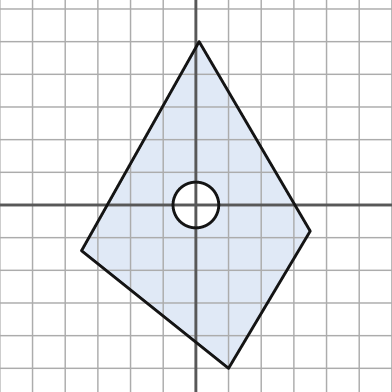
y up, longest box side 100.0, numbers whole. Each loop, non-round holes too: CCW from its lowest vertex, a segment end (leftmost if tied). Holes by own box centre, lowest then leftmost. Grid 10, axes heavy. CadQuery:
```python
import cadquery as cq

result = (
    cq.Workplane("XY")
    .moveTo(10.0, -50.0)
    .lineTo(35.0, -8.0)
    .lineTo(1.0, 50.0)
    .lineTo(-35.0, -14.0)
    .close()
    .moveTo(0.0, 0.0)
    .circle(7.0)
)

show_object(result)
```